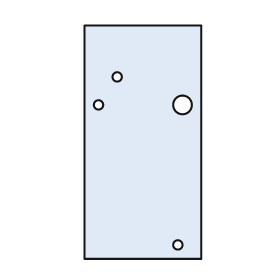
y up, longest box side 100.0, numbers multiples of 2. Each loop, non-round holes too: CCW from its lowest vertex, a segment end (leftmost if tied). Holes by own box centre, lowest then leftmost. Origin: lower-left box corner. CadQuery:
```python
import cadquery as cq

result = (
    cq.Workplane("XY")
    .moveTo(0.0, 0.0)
    .lineTo(50.0, 0.0)
    .lineTo(50.0, 100.0)
    .lineTo(0.0, 100.0)
    .close()
    .moveTo(40.0, 6.0)
    .circle(2.0)
    .moveTo(6.0, 66.0)
    .circle(2.0)
    .moveTo(42.0, 66.0)
    .circle(4.0)
    .moveTo(14.0, 78.0)
    .circle(2.0)
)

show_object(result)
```